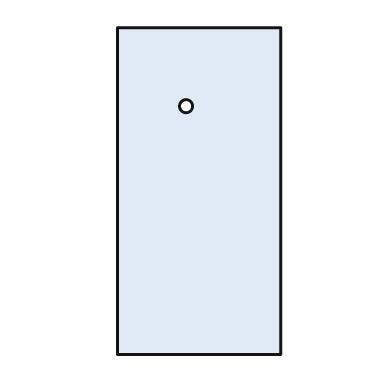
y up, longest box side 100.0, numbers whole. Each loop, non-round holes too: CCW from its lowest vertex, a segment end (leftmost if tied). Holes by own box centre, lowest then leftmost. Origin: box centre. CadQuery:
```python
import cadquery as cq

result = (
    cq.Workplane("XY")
    .moveTo(-25.0, -50.0)
    .lineTo(25.0, -50.0)
    .lineTo(25.0, 50.0)
    .lineTo(-25.0, 50.0)
    .close()
    .moveTo(-4.0, 26.0)
    .circle(2.0)
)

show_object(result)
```